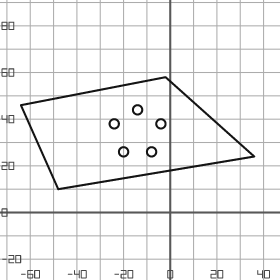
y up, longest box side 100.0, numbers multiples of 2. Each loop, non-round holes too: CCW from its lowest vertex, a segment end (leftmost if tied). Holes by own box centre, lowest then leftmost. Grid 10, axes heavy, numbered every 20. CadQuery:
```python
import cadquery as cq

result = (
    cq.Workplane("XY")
    .moveTo(-48.0, 10.0)
    .lineTo(36.0, 24.0)
    .lineTo(-2.0, 58.0)
    .lineTo(-64.0, 46.0)
    .close()
    .moveTo(-20.0, 26.0)
    .circle(2.0)
    .moveTo(-8.0, 26.0)
    .circle(2.0)
    .moveTo(-24.0, 38.0)
    .circle(2.0)
    .moveTo(-4.0, 38.0)
    .circle(2.0)
    .moveTo(-14.0, 44.0)
    .circle(2.0)
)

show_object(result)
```